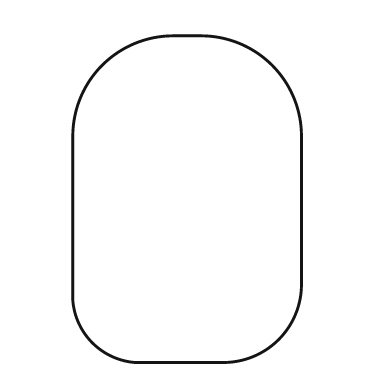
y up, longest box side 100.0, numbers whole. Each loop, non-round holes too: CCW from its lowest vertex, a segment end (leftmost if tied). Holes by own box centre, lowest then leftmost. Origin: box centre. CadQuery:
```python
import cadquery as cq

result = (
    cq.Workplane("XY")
    .moveTo(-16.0, -50.0)
    .lineTo(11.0, -50.0)
    .threePointArc((28.0, -43.0), (35.0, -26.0))
    .lineTo(35.0, 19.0)
    .threePointArc((26.0, 41.0), (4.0, 50.0))
    .lineTo(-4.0, 50.0)
    .threePointArc((-26.0, 41.0), (-35.0, 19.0))
    .lineTo(-35.0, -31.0)
    .threePointArc((-29.0, -44.0), (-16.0, -50.0))
    .close()
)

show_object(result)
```